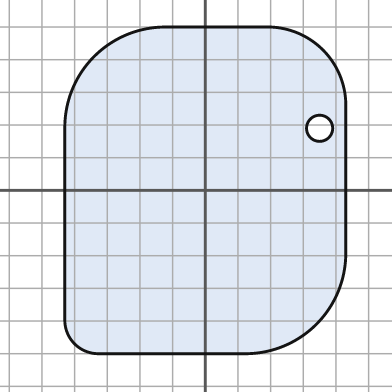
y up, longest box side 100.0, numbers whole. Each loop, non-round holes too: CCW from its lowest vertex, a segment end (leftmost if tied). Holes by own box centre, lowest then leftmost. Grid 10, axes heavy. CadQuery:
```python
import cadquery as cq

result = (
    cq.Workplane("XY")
    .moveTo(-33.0, -50.0)
    .lineTo(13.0, -50.0)
    .threePointArc((34.0, -41.0), (43.0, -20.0))
    .lineTo(43.0, 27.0)
    .threePointArc((36.0, 43.0), (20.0, 50.0))
    .lineTo(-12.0, 50.0)
    .threePointArc((-34.0, 41.0), (-43.0, 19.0))
    .lineTo(-43.0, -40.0)
    .threePointArc((-40.0, -47.0), (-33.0, -50.0))
    .close()
    .moveTo(35.0, 19.0)
    .circle(4.0)
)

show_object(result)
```